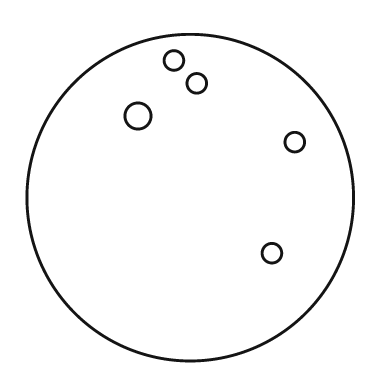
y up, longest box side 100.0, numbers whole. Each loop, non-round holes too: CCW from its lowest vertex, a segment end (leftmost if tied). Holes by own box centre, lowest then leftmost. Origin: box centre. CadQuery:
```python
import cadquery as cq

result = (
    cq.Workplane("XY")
    .moveTo(0.0, 0.0)
    .circle(50.0)
    .moveTo(25.0, -17.0)
    .circle(3.0)
    .moveTo(32.0, 17.0)
    .circle(3.0)
    .moveTo(-16.0, 25.0)
    .circle(4.0)
    .moveTo(2.0, 35.0)
    .circle(3.0)
    .moveTo(-5.0, 42.0)
    .circle(3.0)
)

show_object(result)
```